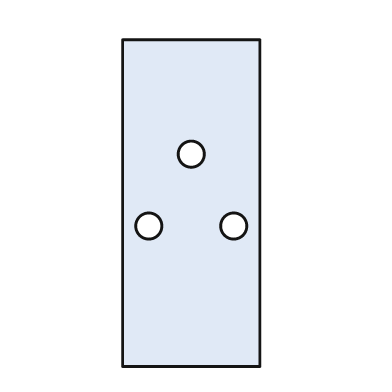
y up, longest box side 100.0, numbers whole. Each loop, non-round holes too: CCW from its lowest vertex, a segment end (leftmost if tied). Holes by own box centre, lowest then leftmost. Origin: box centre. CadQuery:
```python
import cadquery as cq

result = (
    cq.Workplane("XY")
    .moveTo(-21.0, -50.0)
    .lineTo(21.0, -50.0)
    .lineTo(21.0, 50.0)
    .lineTo(-21.0, 50.0)
    .close()
    .moveTo(-13.0, -7.0)
    .circle(4.0)
    .moveTo(13.0, -7.0)
    .circle(4.0)
    .moveTo(0.0, 15.0)
    .circle(4.0)
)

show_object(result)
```